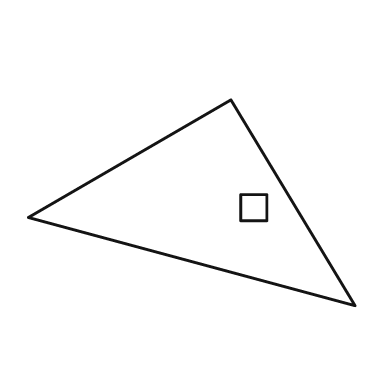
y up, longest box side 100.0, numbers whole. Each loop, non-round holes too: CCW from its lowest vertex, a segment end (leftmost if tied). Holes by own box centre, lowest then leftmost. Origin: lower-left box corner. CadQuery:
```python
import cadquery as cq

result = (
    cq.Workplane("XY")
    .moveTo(100.0, 0.0)
    .lineTo(62.0, 63.0)
    .lineTo(0.0, 27.0)
    .close()
    .moveTo(65.0, 26.0)
    .lineTo(73.0, 26.0)
    .lineTo(73.0, 34.0)
    .lineTo(65.0, 34.0)
    .close()
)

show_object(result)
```